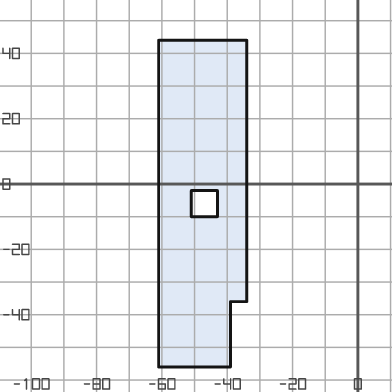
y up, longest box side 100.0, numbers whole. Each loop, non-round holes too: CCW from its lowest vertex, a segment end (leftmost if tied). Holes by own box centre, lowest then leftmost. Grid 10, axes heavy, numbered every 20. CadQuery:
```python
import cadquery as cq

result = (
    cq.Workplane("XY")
    .moveTo(-61.0, -56.0)
    .lineTo(-39.0, -56.0)
    .lineTo(-39.0, -36.0)
    .lineTo(-34.0, -36.0)
    .lineTo(-34.0, 44.0)
    .lineTo(-61.0, 44.0)
    .close()
    .moveTo(-51.0, -10.0)
    .lineTo(-43.0, -10.0)
    .lineTo(-43.0, -2.0)
    .lineTo(-51.0, -2.0)
    .close()
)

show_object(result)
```